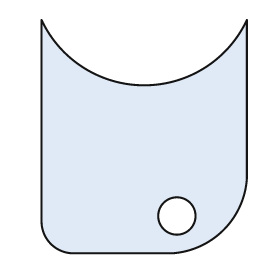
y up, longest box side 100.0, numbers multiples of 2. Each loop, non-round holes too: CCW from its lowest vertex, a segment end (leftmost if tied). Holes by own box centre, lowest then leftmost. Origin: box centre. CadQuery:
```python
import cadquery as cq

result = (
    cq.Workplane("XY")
    .moveTo(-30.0, -50.0)
    .lineTo(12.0, -50.0)
    .threePointArc((34.0, -40.0), (44.0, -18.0))
    .lineTo(44.0, 50.0)
    .threePointArc((0.0, 22.0), (-44.0, 50.0))
    .lineTo(-44.0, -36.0)
    .threePointArc((-40.0, -46.0), (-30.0, -50.0))
    .close()
    .moveTo(14.0, -34.0)
    .circle(8.0)
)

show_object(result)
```